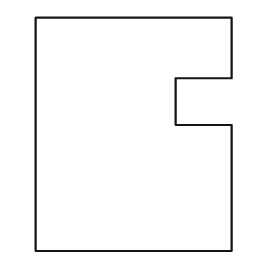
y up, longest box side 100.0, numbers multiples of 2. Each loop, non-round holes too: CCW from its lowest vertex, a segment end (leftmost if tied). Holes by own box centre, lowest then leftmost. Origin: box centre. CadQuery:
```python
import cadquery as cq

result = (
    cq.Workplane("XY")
    .moveTo(-42.0, -50.0)
    .lineTo(42.0, -50.0)
    .lineTo(42.0, 4.0)
    .lineTo(18.0, 4.0)
    .lineTo(18.0, 24.0)
    .lineTo(42.0, 24.0)
    .lineTo(42.0, 50.0)
    .lineTo(-42.0, 50.0)
    .close()
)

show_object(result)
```